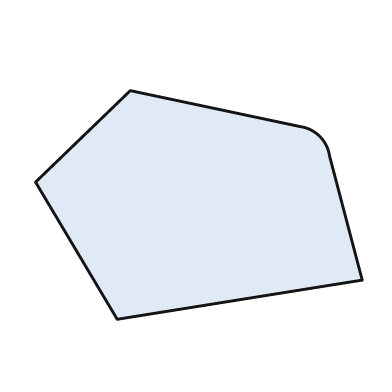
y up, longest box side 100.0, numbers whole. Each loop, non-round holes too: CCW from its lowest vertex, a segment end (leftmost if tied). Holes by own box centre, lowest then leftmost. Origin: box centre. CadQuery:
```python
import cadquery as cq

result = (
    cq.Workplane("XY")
    .moveTo(-25.0, -35.0)
    .lineTo(50.0, -23.0)
    .lineTo(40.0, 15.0)
    .threePointArc((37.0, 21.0), (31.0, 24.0))
    .lineTo(-21.0, 35.0)
    .lineTo(-50.0, 7.0)
    .close()
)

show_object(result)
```